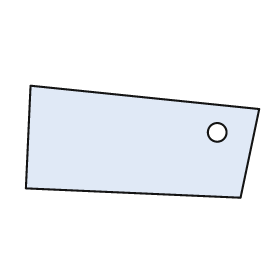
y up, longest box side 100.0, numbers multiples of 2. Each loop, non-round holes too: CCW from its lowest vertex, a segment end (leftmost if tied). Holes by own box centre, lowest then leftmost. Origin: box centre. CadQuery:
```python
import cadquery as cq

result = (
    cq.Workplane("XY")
    .moveTo(42.0, -24.0)
    .lineTo(50.0, 14.0)
    .lineTo(-48.0, 24.0)
    .lineTo(-50.0, -20.0)
    .close()
    .moveTo(32.0, 4.0)
    .circle(4.0)
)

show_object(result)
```